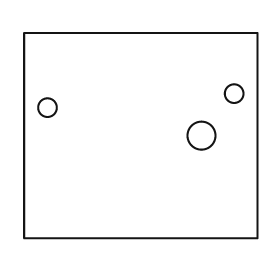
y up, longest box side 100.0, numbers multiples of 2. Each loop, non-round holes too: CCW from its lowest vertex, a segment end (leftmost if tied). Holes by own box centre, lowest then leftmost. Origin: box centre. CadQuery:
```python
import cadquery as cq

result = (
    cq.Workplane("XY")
    .moveTo(-50.0, -44.0)
    .lineTo(50.0, -44.0)
    .lineTo(50.0, 44.0)
    .lineTo(-50.0, 44.0)
    .close()
    .moveTo(26.0, 0.0)
    .circle(6.0)
    .moveTo(-40.0, 12.0)
    .circle(4.0)
    .moveTo(40.0, 18.0)
    .circle(4.0)
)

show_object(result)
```